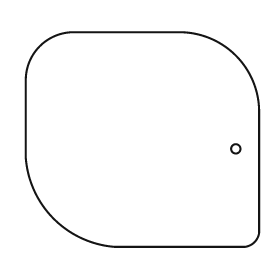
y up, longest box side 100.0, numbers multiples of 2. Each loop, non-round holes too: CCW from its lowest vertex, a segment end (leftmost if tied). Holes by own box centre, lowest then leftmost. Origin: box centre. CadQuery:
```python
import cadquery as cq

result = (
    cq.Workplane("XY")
    .moveTo(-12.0, -46.0)
    .lineTo(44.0, -46.0)
    .threePointArc((48.0, -44.0), (50.0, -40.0))
    .lineTo(50.0, 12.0)
    .threePointArc((40.0, 36.0), (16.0, 46.0))
    .lineTo(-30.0, 46.0)
    .threePointArc((-44.0, 40.0), (-50.0, 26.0))
    .lineTo(-50.0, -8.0)
    .threePointArc((-38.0, -34.0), (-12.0, -46.0))
    .close()
    .moveTo(40.0, -4.0)
    .circle(2.0)
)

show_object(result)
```